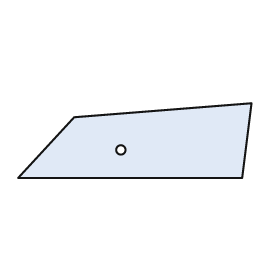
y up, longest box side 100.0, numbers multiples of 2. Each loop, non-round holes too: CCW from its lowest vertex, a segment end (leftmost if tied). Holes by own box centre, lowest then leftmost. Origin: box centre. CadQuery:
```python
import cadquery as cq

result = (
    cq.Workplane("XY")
    .moveTo(-50.0, -16.0)
    .lineTo(46.0, -16.0)
    .lineTo(50.0, 16.0)
    .lineTo(-26.0, 10.0)
    .close()
    .moveTo(-6.0, -4.0)
    .circle(2.0)
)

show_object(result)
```